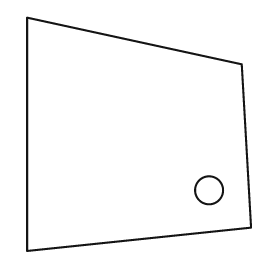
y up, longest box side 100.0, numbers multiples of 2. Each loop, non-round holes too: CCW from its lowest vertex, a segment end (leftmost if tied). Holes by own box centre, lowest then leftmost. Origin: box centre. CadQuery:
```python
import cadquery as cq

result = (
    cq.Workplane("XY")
    .moveTo(-48.0, -50.0)
    .lineTo(48.0, -40.0)
    .lineTo(44.0, 30.0)
    .lineTo(-48.0, 50.0)
    .close()
    .moveTo(30.0, -24.0)
    .circle(6.0)
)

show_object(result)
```